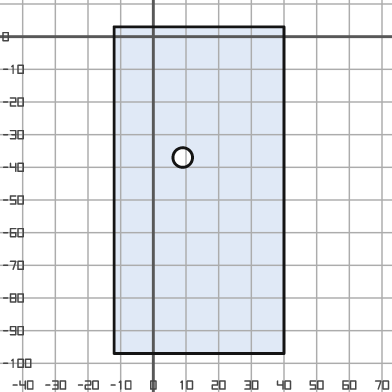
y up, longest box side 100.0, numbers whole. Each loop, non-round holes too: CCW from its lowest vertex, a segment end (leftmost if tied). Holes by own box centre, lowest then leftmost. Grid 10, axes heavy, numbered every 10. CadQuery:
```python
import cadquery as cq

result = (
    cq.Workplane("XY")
    .moveTo(-12.0, -97.0)
    .lineTo(40.0, -97.0)
    .lineTo(40.0, 3.0)
    .lineTo(-12.0, 3.0)
    .close()
    .moveTo(9.0, -37.0)
    .circle(3.0)
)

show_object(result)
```